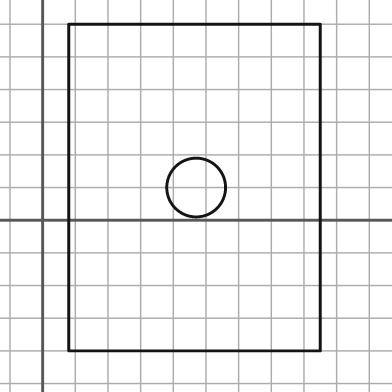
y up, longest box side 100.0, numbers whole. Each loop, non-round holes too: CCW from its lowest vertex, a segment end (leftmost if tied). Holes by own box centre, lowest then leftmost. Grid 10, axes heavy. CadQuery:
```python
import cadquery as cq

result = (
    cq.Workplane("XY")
    .moveTo(8.0, -40.0)
    .lineTo(85.0, -40.0)
    .lineTo(85.0, 60.0)
    .lineTo(8.0, 60.0)
    .close()
    .moveTo(47.0, 10.0)
    .circle(9.0)
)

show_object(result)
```